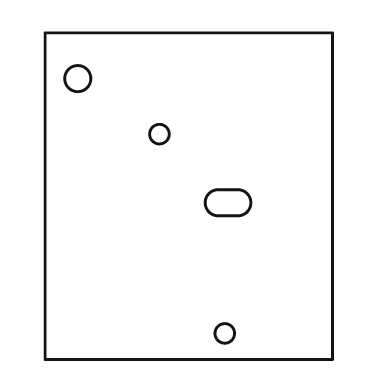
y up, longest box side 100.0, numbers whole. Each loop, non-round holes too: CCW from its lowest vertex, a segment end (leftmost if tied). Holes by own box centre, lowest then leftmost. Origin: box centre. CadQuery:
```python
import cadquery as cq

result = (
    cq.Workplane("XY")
    .moveTo(-44.0, -50.0)
    .lineTo(44.0, -50.0)
    .lineTo(44.0, 50.0)
    .lineTo(-44.0, 50.0)
    .close()
    .moveTo(11.0, -42.0)
    .circle(3.0)
    .moveTo(9.0, -6.0)
    .lineTo(15.0, -6.0)
    .threePointArc((19.0, -2.0), (15.0, 2.0))
    .lineTo(9.0, 2.0)
    .threePointArc((5.0, -2.0), (9.0, -6.0))
    .close()
    .moveTo(-9.0, 19.0)
    .circle(3.0)
    .moveTo(-34.0, 36.0)
    .circle(4.0)
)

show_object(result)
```